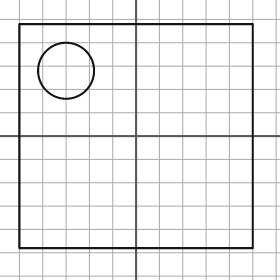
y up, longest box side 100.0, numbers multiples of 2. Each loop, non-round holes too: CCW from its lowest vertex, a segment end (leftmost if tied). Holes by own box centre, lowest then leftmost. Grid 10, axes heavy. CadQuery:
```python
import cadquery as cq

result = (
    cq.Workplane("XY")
    .moveTo(-50.0, -48.0)
    .lineTo(50.0, -48.0)
    .lineTo(50.0, 48.0)
    .lineTo(-50.0, 48.0)
    .close()
    .moveTo(-30.0, 28.0)
    .circle(12.0)
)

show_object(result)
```